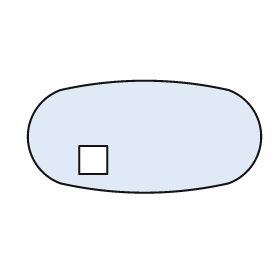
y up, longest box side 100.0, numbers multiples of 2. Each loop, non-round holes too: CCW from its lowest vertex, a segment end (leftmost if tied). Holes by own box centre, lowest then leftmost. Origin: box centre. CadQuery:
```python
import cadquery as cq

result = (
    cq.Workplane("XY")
    .moveTo(-36.0, -20.0)
    .threePointArc((0.0, -24.0), (36.0, -20.0))
    .threePointArc((50.0, 0.0), (36.0, 20.0))
    .threePointArc((0.0, 24.0), (-36.0, 20.0))
    .threePointArc((-50.0, 0.0), (-36.0, -20.0))
    .close()
    .moveTo(-28.0, -16.0)
    .lineTo(-16.0, -16.0)
    .lineTo(-16.0, -4.0)
    .lineTo(-28.0, -4.0)
    .close()
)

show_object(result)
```